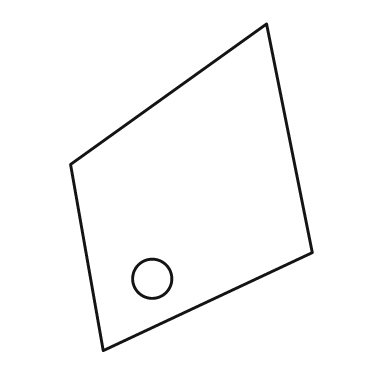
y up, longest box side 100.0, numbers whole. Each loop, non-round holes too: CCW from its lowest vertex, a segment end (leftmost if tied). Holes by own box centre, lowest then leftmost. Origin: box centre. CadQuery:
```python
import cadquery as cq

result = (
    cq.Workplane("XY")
    .moveTo(-27.0, -50.0)
    .lineTo(37.0, -20.0)
    .lineTo(23.0, 50.0)
    .lineTo(-37.0, 7.0)
    .close()
    .moveTo(-12.0, -28.0)
    .circle(6.0)
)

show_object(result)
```